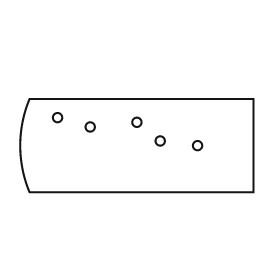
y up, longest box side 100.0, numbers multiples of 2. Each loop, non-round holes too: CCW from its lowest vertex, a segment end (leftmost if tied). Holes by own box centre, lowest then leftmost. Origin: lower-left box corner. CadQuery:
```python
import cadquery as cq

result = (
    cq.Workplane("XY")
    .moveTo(4.0, 0.0)
    .lineTo(100.0, 0.0)
    .lineTo(100.0, 40.0)
    .lineTo(4.0, 40.0)
    .threePointArc((0.0, 20.0), (4.0, 0.0))
    .close()
    .moveTo(76.0, 20.0)
    .circle(2.0)
    .moveTo(60.0, 22.0)
    .circle(2.0)
    .moveTo(30.0, 28.0)
    .circle(2.0)
    .moveTo(50.0, 30.0)
    .circle(2.0)
    .moveTo(16.0, 32.0)
    .circle(2.0)
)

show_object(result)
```